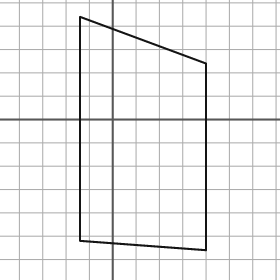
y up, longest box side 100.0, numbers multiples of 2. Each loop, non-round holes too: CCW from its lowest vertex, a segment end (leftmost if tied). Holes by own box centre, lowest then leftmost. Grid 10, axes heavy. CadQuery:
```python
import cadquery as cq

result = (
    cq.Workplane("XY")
    .moveTo(40.0, -56.0)
    .lineTo(40.0, 24.0)
    .lineTo(-14.0, 44.0)
    .lineTo(-14.0, -52.0)
    .close()
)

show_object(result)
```